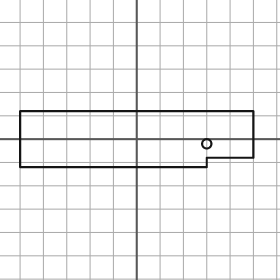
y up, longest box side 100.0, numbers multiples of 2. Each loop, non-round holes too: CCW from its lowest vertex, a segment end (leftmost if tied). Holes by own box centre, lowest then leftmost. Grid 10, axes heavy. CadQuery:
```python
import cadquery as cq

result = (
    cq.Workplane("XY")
    .moveTo(-50.0, -12.0)
    .lineTo(30.0, -12.0)
    .lineTo(30.0, -8.0)
    .lineTo(50.0, -8.0)
    .lineTo(50.0, 12.0)
    .lineTo(-50.0, 12.0)
    .close()
    .moveTo(30.0, -2.0)
    .circle(2.0)
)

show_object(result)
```